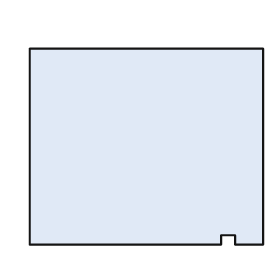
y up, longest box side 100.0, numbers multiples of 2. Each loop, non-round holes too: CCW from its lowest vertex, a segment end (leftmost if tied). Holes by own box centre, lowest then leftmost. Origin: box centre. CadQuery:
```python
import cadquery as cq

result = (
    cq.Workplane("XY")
    .moveTo(-50.0, -42.0)
    .lineTo(32.0, -42.0)
    .lineTo(32.0, -38.0)
    .lineTo(38.0, -38.0)
    .lineTo(38.0, -42.0)
    .lineTo(50.0, -42.0)
    .lineTo(50.0, 42.0)
    .lineTo(-50.0, 42.0)
    .close()
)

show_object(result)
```